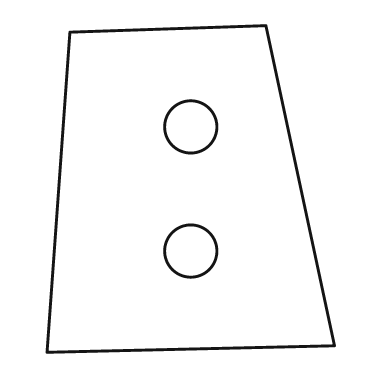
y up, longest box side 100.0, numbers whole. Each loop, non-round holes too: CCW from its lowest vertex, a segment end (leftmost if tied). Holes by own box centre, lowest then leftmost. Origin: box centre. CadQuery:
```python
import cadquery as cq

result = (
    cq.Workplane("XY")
    .moveTo(-44.0, -50.0)
    .lineTo(44.0, -48.0)
    .lineTo(23.0, 50.0)
    .lineTo(-37.0, 48.0)
    .close()
    .moveTo(0.0, -19.0)
    .circle(8.0)
    .moveTo(0.0, 19.0)
    .circle(8.0)
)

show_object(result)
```